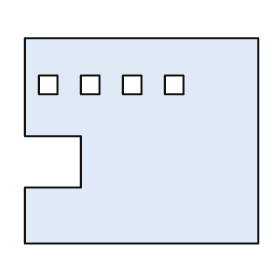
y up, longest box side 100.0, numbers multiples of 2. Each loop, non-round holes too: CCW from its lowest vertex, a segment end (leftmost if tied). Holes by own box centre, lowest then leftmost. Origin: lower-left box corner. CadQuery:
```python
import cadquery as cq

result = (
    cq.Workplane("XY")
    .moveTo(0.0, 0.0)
    .lineTo(100.0, 0.0)
    .lineTo(100.0, 88.0)
    .lineTo(0.0, 88.0)
    .lineTo(0.0, 46.0)
    .lineTo(24.0, 46.0)
    .lineTo(24.0, 24.0)
    .lineTo(0.0, 24.0)
    .close()
    .moveTo(6.0, 64.0)
    .lineTo(14.0, 64.0)
    .lineTo(14.0, 72.0)
    .lineTo(6.0, 72.0)
    .close()
    .moveTo(24.0, 64.0)
    .lineTo(32.0, 64.0)
    .lineTo(32.0, 72.0)
    .lineTo(24.0, 72.0)
    .close()
    .moveTo(42.0, 64.0)
    .lineTo(50.0, 64.0)
    .lineTo(50.0, 72.0)
    .lineTo(42.0, 72.0)
    .close()
    .moveTo(60.0, 64.0)
    .lineTo(68.0, 64.0)
    .lineTo(68.0, 72.0)
    .lineTo(60.0, 72.0)
    .close()
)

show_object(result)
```